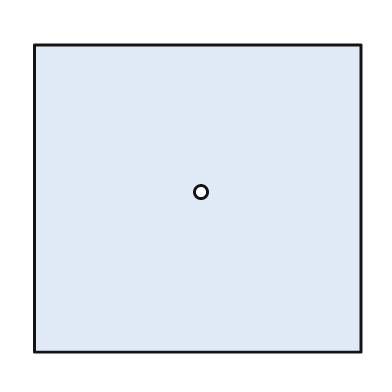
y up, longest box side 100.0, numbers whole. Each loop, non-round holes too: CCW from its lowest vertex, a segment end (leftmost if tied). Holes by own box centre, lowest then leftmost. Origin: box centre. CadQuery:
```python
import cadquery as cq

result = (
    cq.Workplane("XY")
    .moveTo(-50.0, -47.0)
    .lineTo(50.0, -47.0)
    .lineTo(50.0, 47.0)
    .lineTo(-50.0, 47.0)
    .close()
    .moveTo(1.0, 2.0)
    .circle(2.0)
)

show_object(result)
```